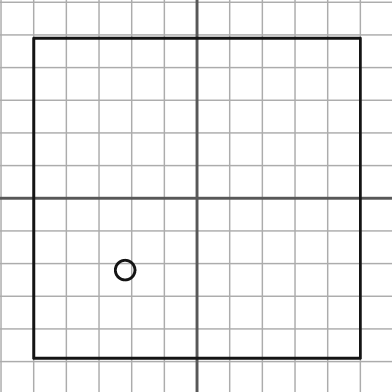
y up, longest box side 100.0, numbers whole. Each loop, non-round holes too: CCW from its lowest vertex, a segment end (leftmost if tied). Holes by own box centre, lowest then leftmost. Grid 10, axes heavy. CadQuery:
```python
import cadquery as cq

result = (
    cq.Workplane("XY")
    .moveTo(-50.0, -49.0)
    .lineTo(50.0, -49.0)
    .lineTo(50.0, 49.0)
    .lineTo(-50.0, 49.0)
    .close()
    .moveTo(-22.0, -22.0)
    .circle(3.0)
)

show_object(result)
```